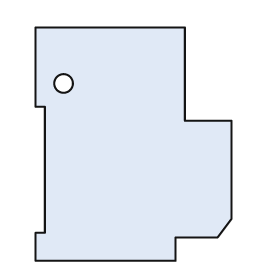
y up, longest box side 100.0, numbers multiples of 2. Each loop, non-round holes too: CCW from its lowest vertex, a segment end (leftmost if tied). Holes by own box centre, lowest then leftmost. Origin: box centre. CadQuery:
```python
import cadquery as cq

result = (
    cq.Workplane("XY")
    .moveTo(-42.0, -50.0)
    .lineTo(18.0, -50.0)
    .lineTo(18.0, -40.0)
    .lineTo(36.0, -40.0)
    .lineTo(42.0, -32.0)
    .lineTo(42.0, 10.0)
    .lineTo(22.0, 10.0)
    .lineTo(22.0, 50.0)
    .lineTo(-42.0, 50.0)
    .lineTo(-42.0, 16.0)
    .lineTo(-38.0, 16.0)
    .lineTo(-38.0, -38.0)
    .lineTo(-42.0, -38.0)
    .close()
    .moveTo(-30.0, 26.0)
    .circle(4.0)
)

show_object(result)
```